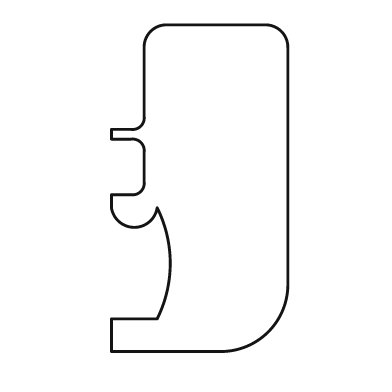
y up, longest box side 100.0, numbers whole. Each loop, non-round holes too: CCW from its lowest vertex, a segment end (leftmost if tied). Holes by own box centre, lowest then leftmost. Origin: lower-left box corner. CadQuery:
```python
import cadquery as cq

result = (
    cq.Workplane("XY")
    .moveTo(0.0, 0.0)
    .lineTo(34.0, 0.0)
    .threePointArc((48.0, 6.0), (54.0, 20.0))
    .lineTo(54.0, 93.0)
    .threePointArc((52.0, 98.0), (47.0, 100.0))
    .lineTo(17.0, 100.0)
    .threePointArc((12.0, 98.0), (10.0, 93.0))
    .lineTo(10.0, 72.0)
    .threePointArc((9.0, 69.0), (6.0, 68.0))
    .lineTo(0.0, 68.0)
    .lineTo(0.0, 65.0)
    .lineTo(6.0, 65.0)
    .threePointArc((9.0, 64.0), (10.0, 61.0))
    .lineTo(10.0, 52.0)
    .threePointArc((9.0, 49.0), (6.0, 48.0))
    .lineTo(0.0, 48.0)
    .lineTo(0.0, 44.0)
    .threePointArc((7.0, 38.0), (14.0, 44.0))
    .threePointArc((18.0, 27.0), (14.0, 10.0))
    .lineTo(0.0, 10.0)
    .close()
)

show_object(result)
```